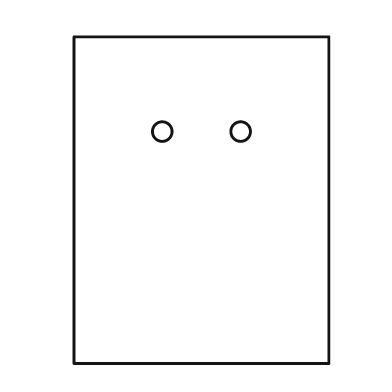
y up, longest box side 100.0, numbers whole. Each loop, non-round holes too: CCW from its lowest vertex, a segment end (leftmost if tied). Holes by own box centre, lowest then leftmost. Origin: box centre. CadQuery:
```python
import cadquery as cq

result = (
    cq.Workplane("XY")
    .moveTo(-39.0, -50.0)
    .lineTo(39.0, -50.0)
    .lineTo(39.0, 50.0)
    .lineTo(-39.0, 50.0)
    .close()
    .moveTo(-12.0, 21.0)
    .circle(3.0)
    .moveTo(12.0, 21.0)
    .circle(3.0)
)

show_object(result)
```